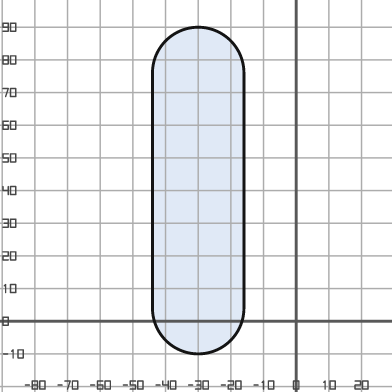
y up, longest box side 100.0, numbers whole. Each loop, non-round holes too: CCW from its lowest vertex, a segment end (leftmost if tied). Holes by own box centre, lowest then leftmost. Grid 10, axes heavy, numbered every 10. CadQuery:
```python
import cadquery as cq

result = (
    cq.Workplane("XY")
    .moveTo(-44.0, 4.0)
    .threePointArc((-30.0, -10.0), (-16.0, 4.0))
    .lineTo(-16.0, 76.0)
    .threePointArc((-30.0, 90.0), (-44.0, 76.0))
    .close()
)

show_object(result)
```